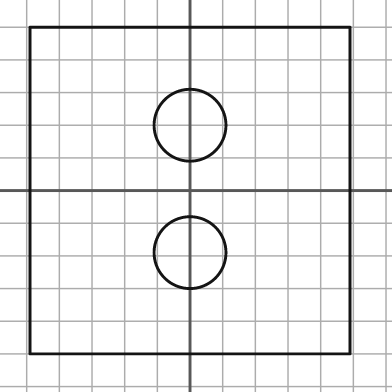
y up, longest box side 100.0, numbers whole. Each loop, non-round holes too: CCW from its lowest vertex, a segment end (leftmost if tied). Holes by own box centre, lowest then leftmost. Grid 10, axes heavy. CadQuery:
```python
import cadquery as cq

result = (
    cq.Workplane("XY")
    .moveTo(-49.0, -50.0)
    .lineTo(49.0, -50.0)
    .lineTo(49.0, 50.0)
    .lineTo(-49.0, 50.0)
    .close()
    .moveTo(0.0, -19.0)
    .circle(11.0)
    .moveTo(0.0, 20.0)
    .circle(11.0)
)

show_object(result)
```